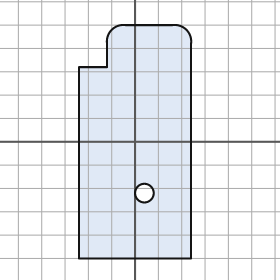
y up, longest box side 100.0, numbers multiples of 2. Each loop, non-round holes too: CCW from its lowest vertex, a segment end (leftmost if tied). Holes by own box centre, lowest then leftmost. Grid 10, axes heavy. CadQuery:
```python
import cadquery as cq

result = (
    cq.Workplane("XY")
    .moveTo(-24.0, -50.0)
    .lineTo(24.0, -50.0)
    .lineTo(24.0, 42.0)
    .threePointArc((22.0, 48.0), (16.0, 50.0))
    .lineTo(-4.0, 50.0)
    .threePointArc((-10.0, 48.0), (-12.0, 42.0))
    .lineTo(-12.0, 32.0)
    .lineTo(-24.0, 32.0)
    .close()
    .moveTo(4.0, -22.0)
    .circle(4.0)
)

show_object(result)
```